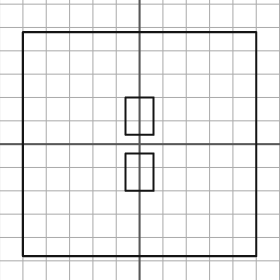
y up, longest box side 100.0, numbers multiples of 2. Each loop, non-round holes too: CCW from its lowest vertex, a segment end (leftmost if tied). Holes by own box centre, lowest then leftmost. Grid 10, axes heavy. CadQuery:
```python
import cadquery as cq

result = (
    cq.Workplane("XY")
    .moveTo(-50.0, -48.0)
    .lineTo(50.0, -48.0)
    .lineTo(50.0, 48.0)
    .lineTo(-50.0, 48.0)
    .close()
    .moveTo(-6.0, -20.0)
    .lineTo(6.0, -20.0)
    .lineTo(6.0, -4.0)
    .lineTo(-6.0, -4.0)
    .close()
    .moveTo(-6.0, 4.0)
    .lineTo(6.0, 4.0)
    .lineTo(6.0, 20.0)
    .lineTo(-6.0, 20.0)
    .close()
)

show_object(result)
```